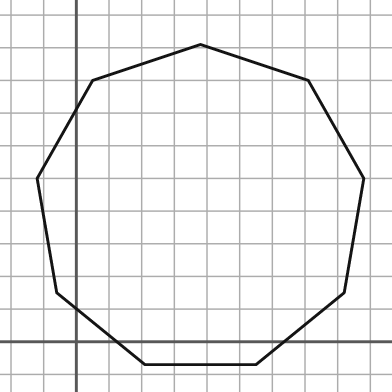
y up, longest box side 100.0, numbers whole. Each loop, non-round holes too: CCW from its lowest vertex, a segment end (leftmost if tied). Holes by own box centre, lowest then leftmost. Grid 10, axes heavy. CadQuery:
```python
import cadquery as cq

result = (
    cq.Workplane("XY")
    .moveTo(21.0, -7.0)
    .lineTo(55.0, -7.0)
    .lineTo(82.0, 15.0)
    .lineTo(88.0, 50.0)
    .lineTo(71.0, 80.0)
    .lineTo(38.0, 91.0)
    .lineTo(5.0, 80.0)
    .lineTo(-12.0, 50.0)
    .lineTo(-6.0, 15.0)
    .close()
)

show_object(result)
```